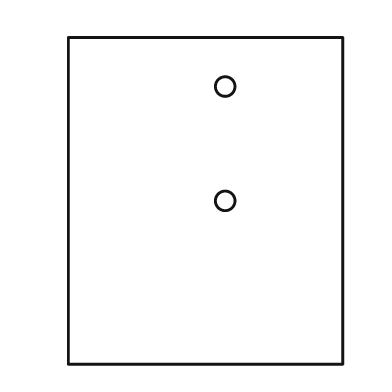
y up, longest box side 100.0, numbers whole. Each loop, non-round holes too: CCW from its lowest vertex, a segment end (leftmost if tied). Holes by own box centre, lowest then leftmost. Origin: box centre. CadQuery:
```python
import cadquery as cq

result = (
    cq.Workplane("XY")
    .moveTo(-42.0, -50.0)
    .lineTo(42.0, -50.0)
    .lineTo(42.0, 50.0)
    .lineTo(-42.0, 50.0)
    .close()
    .moveTo(6.0, 0.0)
    .circle(3.0)
    .moveTo(6.0, 35.0)
    .circle(3.0)
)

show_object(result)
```